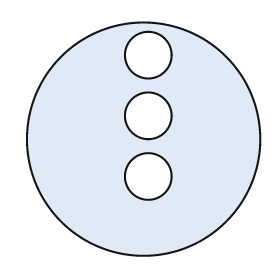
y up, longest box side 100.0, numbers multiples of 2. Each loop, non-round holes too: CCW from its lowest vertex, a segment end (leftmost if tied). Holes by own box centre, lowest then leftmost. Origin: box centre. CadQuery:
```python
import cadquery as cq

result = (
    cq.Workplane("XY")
    .moveTo(0.0, 0.0)
    .circle(50.0)
    .moveTo(2.0, -16.0)
    .circle(10.0)
    .moveTo(2.0, 10.0)
    .circle(10.0)
    .moveTo(2.0, 36.0)
    .circle(10.0)
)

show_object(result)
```